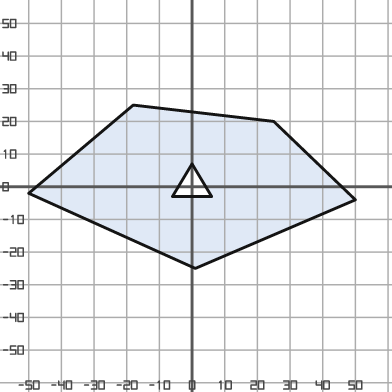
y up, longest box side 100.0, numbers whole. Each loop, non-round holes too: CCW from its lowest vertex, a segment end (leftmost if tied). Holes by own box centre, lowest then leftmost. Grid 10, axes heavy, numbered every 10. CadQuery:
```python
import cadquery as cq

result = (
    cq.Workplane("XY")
    .moveTo(1.0, -25.0)
    .lineTo(50.0, -4.0)
    .lineTo(25.0, 20.0)
    .lineTo(-18.0, 25.0)
    .lineTo(-50.0, -2.0)
    .close()
    .moveTo(-6.0, -3.0)
    .lineTo(6.0, -3.0)
    .lineTo(0.0, 7.0)
    .close()
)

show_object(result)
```